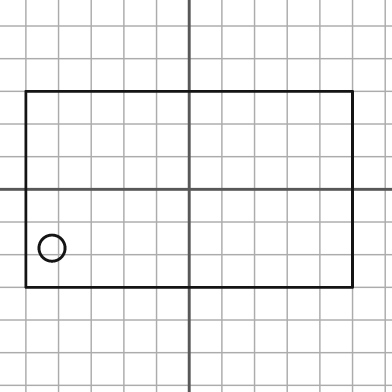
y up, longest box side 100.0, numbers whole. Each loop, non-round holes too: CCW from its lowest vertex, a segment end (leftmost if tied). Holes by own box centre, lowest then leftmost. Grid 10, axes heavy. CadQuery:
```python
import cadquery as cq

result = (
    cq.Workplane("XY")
    .moveTo(-50.0, -30.0)
    .lineTo(50.0, -30.0)
    .lineTo(50.0, 30.0)
    .lineTo(-50.0, 30.0)
    .close()
    .moveTo(-42.0, -18.0)
    .circle(4.0)
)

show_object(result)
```